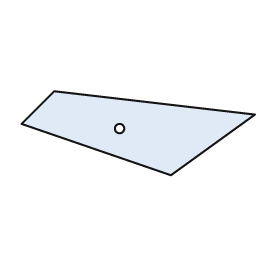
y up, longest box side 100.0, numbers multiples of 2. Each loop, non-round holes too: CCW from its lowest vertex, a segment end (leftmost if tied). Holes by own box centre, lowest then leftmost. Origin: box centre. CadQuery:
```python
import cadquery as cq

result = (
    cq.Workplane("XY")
    .moveTo(14.0, -18.0)
    .lineTo(50.0, 8.0)
    .lineTo(-36.0, 18.0)
    .lineTo(-50.0, 4.0)
    .close()
    .moveTo(-8.0, 2.0)
    .circle(2.0)
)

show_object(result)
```